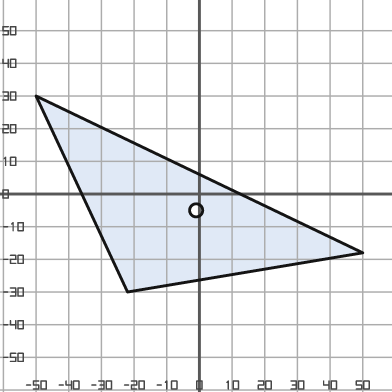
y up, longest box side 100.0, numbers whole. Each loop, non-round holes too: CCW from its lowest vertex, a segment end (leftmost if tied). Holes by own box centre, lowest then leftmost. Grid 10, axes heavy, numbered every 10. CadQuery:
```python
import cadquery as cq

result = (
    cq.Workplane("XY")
    .moveTo(-22.0, -30.0)
    .lineTo(50.0, -18.0)
    .lineTo(-50.0, 30.0)
    .close()
    .moveTo(-1.0, -5.0)
    .circle(2.0)
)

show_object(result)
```